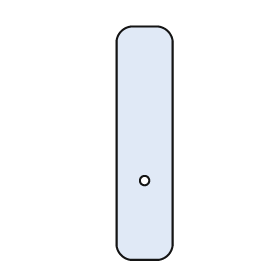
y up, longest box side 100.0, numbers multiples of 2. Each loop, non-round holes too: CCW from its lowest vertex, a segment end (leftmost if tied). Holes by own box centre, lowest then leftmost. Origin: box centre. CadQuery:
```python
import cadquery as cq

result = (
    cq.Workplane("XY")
    .moveTo(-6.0, -50.0)
    .lineTo(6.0, -50.0)
    .threePointArc((10.0, -48.0), (12.0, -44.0))
    .lineTo(12.0, 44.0)
    .threePointArc((10.0, 48.0), (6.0, 50.0))
    .lineTo(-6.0, 50.0)
    .threePointArc((-10.0, 48.0), (-12.0, 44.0))
    .lineTo(-12.0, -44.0)
    .threePointArc((-10.0, -48.0), (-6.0, -50.0))
    .close()
    .moveTo(0.0, -16.0)
    .circle(2.0)
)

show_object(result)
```